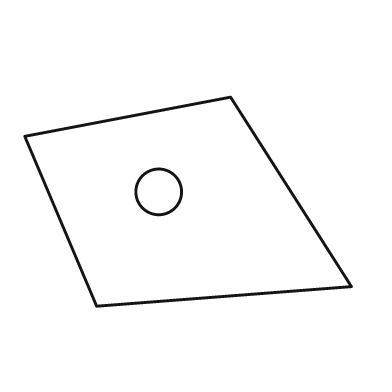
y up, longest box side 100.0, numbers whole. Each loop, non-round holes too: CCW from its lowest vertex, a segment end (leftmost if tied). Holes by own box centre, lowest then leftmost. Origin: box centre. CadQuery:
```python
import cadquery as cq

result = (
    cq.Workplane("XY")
    .moveTo(-28.0, -32.0)
    .lineTo(50.0, -26.0)
    .lineTo(13.0, 32.0)
    .lineTo(-50.0, 20.0)
    .close()
    .moveTo(-9.0, 3.0)
    .circle(7.0)
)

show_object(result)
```